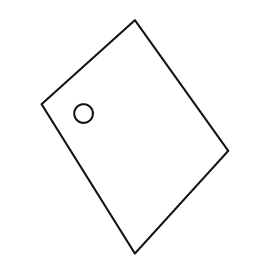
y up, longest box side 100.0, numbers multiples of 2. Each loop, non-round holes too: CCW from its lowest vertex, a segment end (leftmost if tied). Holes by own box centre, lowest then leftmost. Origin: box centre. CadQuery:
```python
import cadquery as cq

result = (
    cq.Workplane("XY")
    .moveTo(0.0, -50.0)
    .lineTo(40.0, -6.0)
    .lineTo(0.0, 50.0)
    .lineTo(-40.0, 14.0)
    .close()
    .moveTo(-22.0, 10.0)
    .circle(4.0)
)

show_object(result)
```